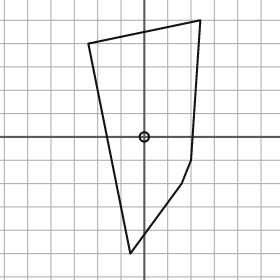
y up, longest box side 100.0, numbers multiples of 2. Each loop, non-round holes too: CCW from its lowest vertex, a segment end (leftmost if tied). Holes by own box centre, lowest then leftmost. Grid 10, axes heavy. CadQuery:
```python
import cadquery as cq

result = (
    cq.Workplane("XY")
    .moveTo(-6.0, -50.0)
    .lineTo(16.0, -20.0)
    .lineTo(20.0, -10.0)
    .lineTo(24.0, 50.0)
    .lineTo(-24.0, 40.0)
    .close()
    .moveTo(0.0, 0.0)
    .circle(2.0)
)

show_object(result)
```